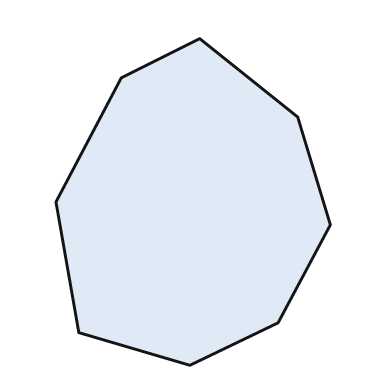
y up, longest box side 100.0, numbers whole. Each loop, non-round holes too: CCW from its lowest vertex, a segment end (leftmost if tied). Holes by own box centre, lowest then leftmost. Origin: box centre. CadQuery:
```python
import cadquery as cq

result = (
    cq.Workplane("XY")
    .moveTo(-1.0, -50.0)
    .lineTo(26.0, -37.0)
    .lineTo(42.0, -7.0)
    .lineTo(32.0, 26.0)
    .lineTo(2.0, 50.0)
    .lineTo(-22.0, 38.0)
    .lineTo(-42.0, 0.0)
    .lineTo(-35.0, -40.0)
    .close()
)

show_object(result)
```